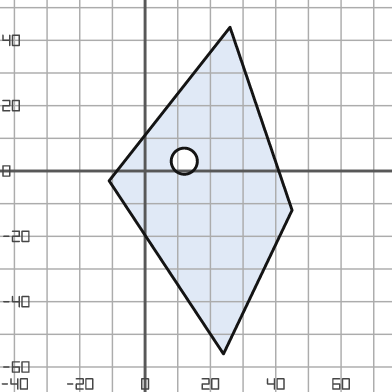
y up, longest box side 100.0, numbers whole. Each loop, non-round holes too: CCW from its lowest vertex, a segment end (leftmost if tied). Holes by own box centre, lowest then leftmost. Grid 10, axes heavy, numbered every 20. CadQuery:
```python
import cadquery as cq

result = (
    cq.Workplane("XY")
    .moveTo(24.0, -56.0)
    .lineTo(45.0, -12.0)
    .lineTo(26.0, 44.0)
    .lineTo(-11.0, -3.0)
    .close()
    .moveTo(12.0, 3.0)
    .circle(4.0)
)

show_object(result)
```